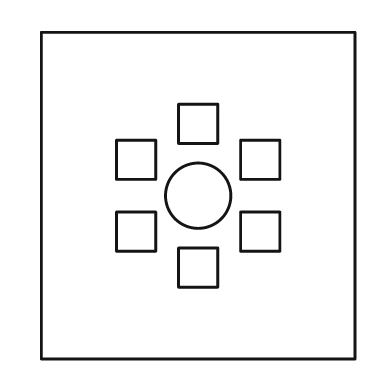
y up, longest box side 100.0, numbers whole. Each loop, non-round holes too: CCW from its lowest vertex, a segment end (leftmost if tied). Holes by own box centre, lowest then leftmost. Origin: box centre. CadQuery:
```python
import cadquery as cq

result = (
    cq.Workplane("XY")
    .moveTo(-48.0, -50.0)
    .lineTo(48.0, -50.0)
    .lineTo(48.0, 50.0)
    .lineTo(-48.0, 50.0)
    .close()
    .moveTo(-6.0, -28.0)
    .lineTo(6.0, -28.0)
    .lineTo(6.0, -16.0)
    .lineTo(-6.0, -16.0)
    .close()
    .moveTo(-25.0, -17.0)
    .lineTo(-13.0, -17.0)
    .lineTo(-13.0, -5.0)
    .lineTo(-25.0, -5.0)
    .close()
    .moveTo(13.0, -17.0)
    .lineTo(25.0, -17.0)
    .lineTo(25.0, -5.0)
    .lineTo(13.0, -5.0)
    .close()
    .moveTo(0.0, 0.0)
    .circle(10.0)
    .moveTo(-25.0, 5.0)
    .lineTo(-13.0, 5.0)
    .lineTo(-13.0, 17.0)
    .lineTo(-25.0, 17.0)
    .close()
    .moveTo(13.0, 5.0)
    .lineTo(25.0, 5.0)
    .lineTo(25.0, 17.0)
    .lineTo(13.0, 17.0)
    .close()
    .moveTo(-6.0, 16.0)
    .lineTo(6.0, 16.0)
    .lineTo(6.0, 28.0)
    .lineTo(-6.0, 28.0)
    .close()
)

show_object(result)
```